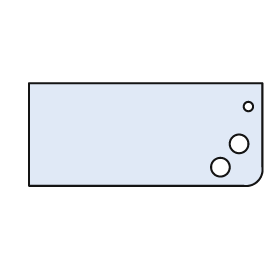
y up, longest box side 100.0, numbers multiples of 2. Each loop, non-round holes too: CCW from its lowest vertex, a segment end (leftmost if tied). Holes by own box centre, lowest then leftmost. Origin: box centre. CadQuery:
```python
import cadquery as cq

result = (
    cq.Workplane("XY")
    .moveTo(-50.0, -22.0)
    .lineTo(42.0, -22.0)
    .threePointArc((48.0, -20.0), (50.0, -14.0))
    .lineTo(50.0, 22.0)
    .lineTo(-50.0, 22.0)
    .close()
    .moveTo(32.0, -14.0)
    .circle(4.0)
    .moveTo(40.0, -4.0)
    .circle(4.0)
    .moveTo(44.0, 12.0)
    .circle(2.0)
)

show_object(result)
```